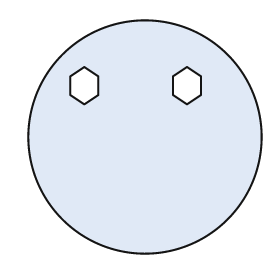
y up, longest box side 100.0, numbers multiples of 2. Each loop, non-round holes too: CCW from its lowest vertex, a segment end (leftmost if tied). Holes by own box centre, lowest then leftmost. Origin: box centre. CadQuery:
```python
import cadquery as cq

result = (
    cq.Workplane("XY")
    .moveTo(0.0, 0.0)
    .circle(50.0)
    .moveTo(-26.0, 14.0)
    .lineTo(-20.0, 18.0)
    .lineTo(-20.0, 26.0)
    .lineTo(-26.0, 30.0)
    .lineTo(-32.0, 26.0)
    .lineTo(-32.0, 18.0)
    .close()
    .moveTo(18.0, 14.0)
    .lineTo(24.0, 18.0)
    .lineTo(24.0, 26.0)
    .lineTo(18.0, 30.0)
    .lineTo(12.0, 26.0)
    .lineTo(12.0, 18.0)
    .close()
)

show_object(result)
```